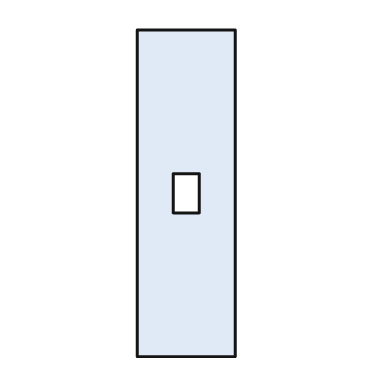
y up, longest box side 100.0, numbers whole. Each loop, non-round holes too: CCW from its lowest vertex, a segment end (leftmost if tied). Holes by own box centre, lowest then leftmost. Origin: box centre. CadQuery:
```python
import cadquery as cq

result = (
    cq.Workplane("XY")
    .moveTo(-15.0, -50.0)
    .lineTo(15.0, -50.0)
    .lineTo(15.0, 50.0)
    .lineTo(-15.0, 50.0)
    .close()
    .moveTo(-4.0, -6.0)
    .lineTo(4.0, -6.0)
    .lineTo(4.0, 6.0)
    .lineTo(-4.0, 6.0)
    .close()
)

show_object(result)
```